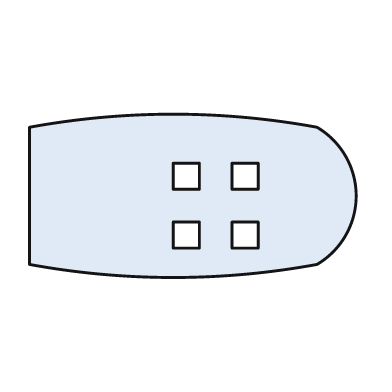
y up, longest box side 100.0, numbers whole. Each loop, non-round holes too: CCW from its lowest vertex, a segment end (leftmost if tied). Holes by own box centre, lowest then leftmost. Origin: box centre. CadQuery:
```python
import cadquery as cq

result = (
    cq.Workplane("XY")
    .moveTo(-50.0, -21.0)
    .threePointArc((-6.0, -25.0), (38.0, -21.0))
    .threePointArc((50.0, 0.0), (38.0, 21.0))
    .threePointArc((-6.0, 25.0), (-50.0, 21.0))
    .close()
    .moveTo(-6.0, -16.0)
    .lineTo(2.0, -16.0)
    .lineTo(2.0, -8.0)
    .lineTo(-6.0, -8.0)
    .close()
    .moveTo(12.0, -16.0)
    .lineTo(20.0, -16.0)
    .lineTo(20.0, -8.0)
    .lineTo(12.0, -8.0)
    .close()
    .moveTo(-6.0, 2.0)
    .lineTo(2.0, 2.0)
    .lineTo(2.0, 10.0)
    .lineTo(-6.0, 10.0)
    .close()
    .moveTo(12.0, 2.0)
    .lineTo(20.0, 2.0)
    .lineTo(20.0, 10.0)
    .lineTo(12.0, 10.0)
    .close()
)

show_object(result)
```